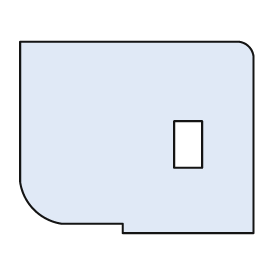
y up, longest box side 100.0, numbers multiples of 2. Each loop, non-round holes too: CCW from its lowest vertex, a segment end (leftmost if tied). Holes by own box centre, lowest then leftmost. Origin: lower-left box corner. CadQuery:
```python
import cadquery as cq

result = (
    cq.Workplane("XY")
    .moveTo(44.0, 0.0)
    .lineTo(100.0, 0.0)
    .lineTo(100.0, 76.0)
    .threePointArc((98.0, 80.0), (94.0, 82.0))
    .lineTo(0.0, 82.0)
    .lineTo(0.0, 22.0)
    .threePointArc((6.0, 10.0), (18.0, 4.0))
    .lineTo(44.0, 4.0)
    .close()
    .moveTo(66.0, 28.0)
    .lineTo(78.0, 28.0)
    .lineTo(78.0, 48.0)
    .lineTo(66.0, 48.0)
    .close()
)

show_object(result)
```